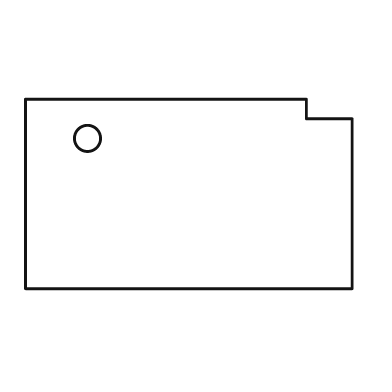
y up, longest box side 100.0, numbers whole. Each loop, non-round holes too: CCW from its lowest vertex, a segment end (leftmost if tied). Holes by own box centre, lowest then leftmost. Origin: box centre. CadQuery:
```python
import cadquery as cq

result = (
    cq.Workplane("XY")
    .moveTo(-50.0, -29.0)
    .lineTo(50.0, -29.0)
    .lineTo(50.0, 23.0)
    .lineTo(36.0, 23.0)
    .lineTo(36.0, 29.0)
    .lineTo(-50.0, 29.0)
    .close()
    .moveTo(-31.0, 17.0)
    .circle(4.0)
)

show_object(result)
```